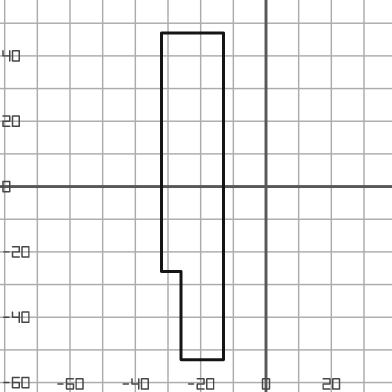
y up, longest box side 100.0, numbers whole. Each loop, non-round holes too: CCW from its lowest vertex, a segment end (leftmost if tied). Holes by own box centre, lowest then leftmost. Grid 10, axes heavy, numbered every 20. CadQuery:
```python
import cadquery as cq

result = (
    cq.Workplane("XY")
    .moveTo(-26.0, -53.0)
    .lineTo(-13.0, -53.0)
    .lineTo(-13.0, 47.0)
    .lineTo(-32.0, 47.0)
    .lineTo(-32.0, -26.0)
    .lineTo(-26.0, -26.0)
    .close()
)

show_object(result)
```